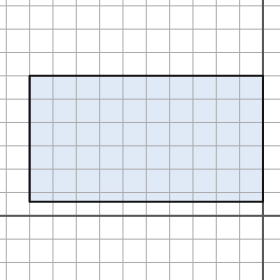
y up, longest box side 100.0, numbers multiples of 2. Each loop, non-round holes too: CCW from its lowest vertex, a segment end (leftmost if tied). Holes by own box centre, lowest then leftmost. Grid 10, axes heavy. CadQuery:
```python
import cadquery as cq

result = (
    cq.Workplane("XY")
    .moveTo(-100.0, 6.0)
    .lineTo(0.0, 6.0)
    .lineTo(0.0, 60.0)
    .lineTo(-100.0, 60.0)
    .close()
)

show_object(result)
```